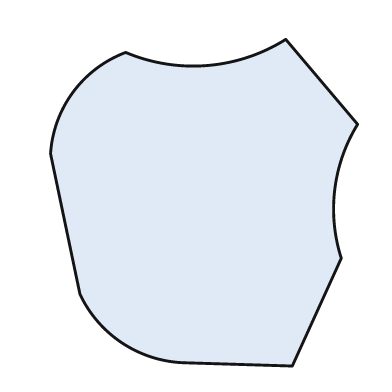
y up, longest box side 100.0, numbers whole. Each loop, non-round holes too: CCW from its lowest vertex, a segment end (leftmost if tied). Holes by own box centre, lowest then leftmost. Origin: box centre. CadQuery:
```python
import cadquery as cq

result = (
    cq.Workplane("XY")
    .moveTo(27.0, -50.0)
    .lineTo(42.0, -17.0)
    .threePointArc((40.0, 4.0), (47.0, 24.0))
    .lineTo(25.0, 50.0)
    .threePointArc((1.0, 42.0), (-24.0, 46.0))
    .threePointArc((-40.0, 34.0), (-47.0, 15.0))
    .lineTo(-38.0, -28.0)
    .threePointArc((-25.0, -43.0), (-6.0, -49.0))
    .close()
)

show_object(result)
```